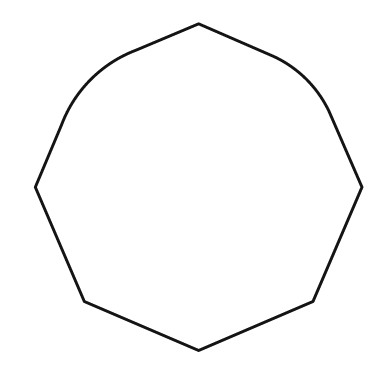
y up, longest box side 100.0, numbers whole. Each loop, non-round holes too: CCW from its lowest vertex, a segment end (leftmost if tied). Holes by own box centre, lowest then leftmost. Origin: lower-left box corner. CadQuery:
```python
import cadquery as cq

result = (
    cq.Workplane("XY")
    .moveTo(50.0, 0.0)
    .lineTo(85.0, 15.0)
    .lineTo(100.0, 50.0)
    .lineTo(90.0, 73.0)
    .threePointArc((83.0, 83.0), (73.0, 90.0))
    .lineTo(50.0, 100.0)
    .lineTo(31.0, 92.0)
    .threePointArc((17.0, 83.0), (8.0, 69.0))
    .lineTo(0.0, 50.0)
    .lineTo(15.0, 15.0)
    .close()
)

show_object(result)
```